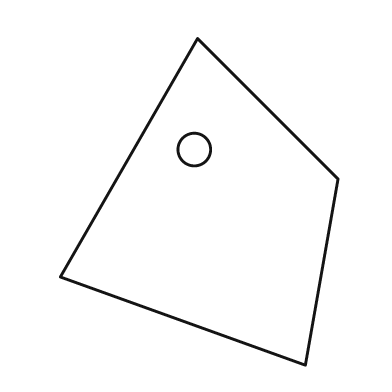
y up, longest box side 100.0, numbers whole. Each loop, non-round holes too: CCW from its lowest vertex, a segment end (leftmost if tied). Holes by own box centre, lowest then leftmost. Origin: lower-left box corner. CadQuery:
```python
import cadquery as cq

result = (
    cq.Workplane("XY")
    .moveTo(75.0, 0.0)
    .lineTo(85.0, 57.0)
    .lineTo(42.0, 100.0)
    .lineTo(0.0, 27.0)
    .close()
    .moveTo(41.0, 66.0)
    .circle(5.0)
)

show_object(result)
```